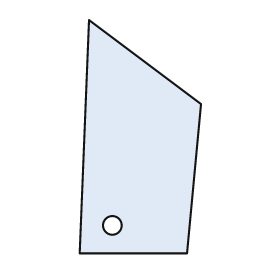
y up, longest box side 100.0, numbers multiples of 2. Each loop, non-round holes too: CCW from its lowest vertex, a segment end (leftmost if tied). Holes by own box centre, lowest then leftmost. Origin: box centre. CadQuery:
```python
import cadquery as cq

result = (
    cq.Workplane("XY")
    .moveTo(-26.0, -50.0)
    .lineTo(20.0, -50.0)
    .lineTo(26.0, 14.0)
    .lineTo(-22.0, 50.0)
    .close()
    .moveTo(-12.0, -38.0)
    .circle(4.0)
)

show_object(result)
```